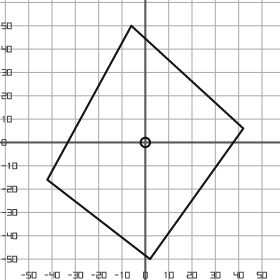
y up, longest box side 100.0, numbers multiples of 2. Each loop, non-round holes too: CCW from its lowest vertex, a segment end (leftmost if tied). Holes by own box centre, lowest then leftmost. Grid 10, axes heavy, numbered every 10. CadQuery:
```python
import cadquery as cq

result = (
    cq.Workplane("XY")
    .moveTo(2.0, -50.0)
    .lineTo(42.0, 6.0)
    .lineTo(-6.0, 50.0)
    .lineTo(-42.0, -16.0)
    .close()
    .moveTo(0.0, 0.0)
    .circle(2.0)
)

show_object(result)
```